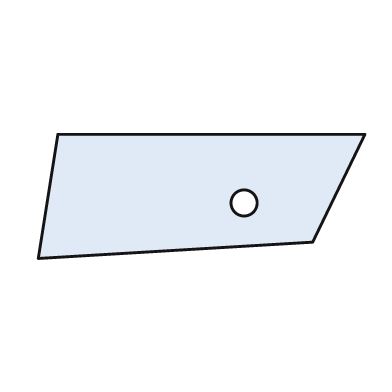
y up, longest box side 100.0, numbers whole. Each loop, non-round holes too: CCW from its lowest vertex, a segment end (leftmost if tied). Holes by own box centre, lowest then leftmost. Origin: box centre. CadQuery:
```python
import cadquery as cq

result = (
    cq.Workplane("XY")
    .moveTo(-50.0, -19.0)
    .lineTo(34.0, -14.0)
    .lineTo(50.0, 19.0)
    .lineTo(-44.0, 19.0)
    .close()
    .moveTo(13.0, -2.0)
    .circle(4.0)
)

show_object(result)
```